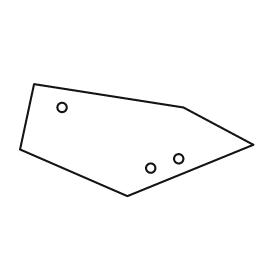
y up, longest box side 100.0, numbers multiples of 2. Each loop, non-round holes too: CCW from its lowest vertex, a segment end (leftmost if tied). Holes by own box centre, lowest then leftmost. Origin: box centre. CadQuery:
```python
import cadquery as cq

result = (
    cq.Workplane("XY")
    .moveTo(-4.0, -24.0)
    .lineTo(50.0, -2.0)
    .lineTo(20.0, 14.0)
    .lineTo(-44.0, 24.0)
    .lineTo(-50.0, -4.0)
    .close()
    .moveTo(6.0, -12.0)
    .circle(2.0)
    .moveTo(18.0, -8.0)
    .circle(2.0)
    .moveTo(-32.0, 14.0)
    .circle(2.0)
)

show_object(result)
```